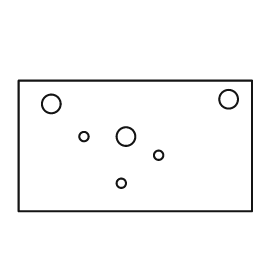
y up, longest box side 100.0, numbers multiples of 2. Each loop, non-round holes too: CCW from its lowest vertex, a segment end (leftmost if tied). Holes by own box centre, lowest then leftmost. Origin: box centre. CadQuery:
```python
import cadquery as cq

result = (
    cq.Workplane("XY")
    .moveTo(-50.0, -28.0)
    .lineTo(50.0, -28.0)
    .lineTo(50.0, 28.0)
    .lineTo(-50.0, 28.0)
    .close()
    .moveTo(-6.0, -16.0)
    .circle(2.0)
    .moveTo(10.0, -4.0)
    .circle(2.0)
    .moveTo(-22.0, 4.0)
    .circle(2.0)
    .moveTo(-4.0, 4.0)
    .circle(4.0)
    .moveTo(-36.0, 18.0)
    .circle(4.0)
    .moveTo(40.0, 20.0)
    .circle(4.0)
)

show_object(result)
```